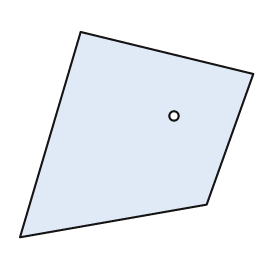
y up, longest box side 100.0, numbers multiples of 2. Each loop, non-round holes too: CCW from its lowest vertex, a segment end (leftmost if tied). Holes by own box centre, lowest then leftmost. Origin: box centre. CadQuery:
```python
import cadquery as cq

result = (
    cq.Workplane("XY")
    .moveTo(-50.0, -44.0)
    .lineTo(30.0, -30.0)
    .lineTo(50.0, 26.0)
    .lineTo(-24.0, 44.0)
    .close()
    .moveTo(16.0, 8.0)
    .circle(2.0)
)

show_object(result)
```